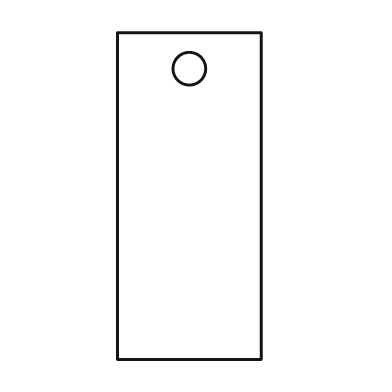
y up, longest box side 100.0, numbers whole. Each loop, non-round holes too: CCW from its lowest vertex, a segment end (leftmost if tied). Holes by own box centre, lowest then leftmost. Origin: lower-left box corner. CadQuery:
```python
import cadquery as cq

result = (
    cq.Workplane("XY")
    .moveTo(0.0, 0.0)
    .lineTo(44.0, 0.0)
    .lineTo(44.0, 100.0)
    .lineTo(0.0, 100.0)
    .close()
    .moveTo(22.0, 89.0)
    .circle(5.0)
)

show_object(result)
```